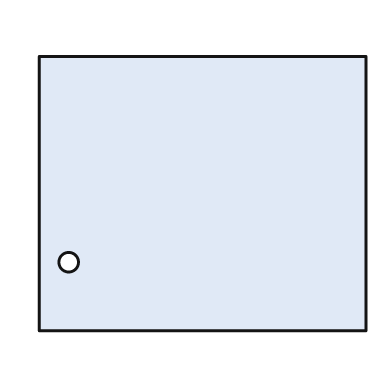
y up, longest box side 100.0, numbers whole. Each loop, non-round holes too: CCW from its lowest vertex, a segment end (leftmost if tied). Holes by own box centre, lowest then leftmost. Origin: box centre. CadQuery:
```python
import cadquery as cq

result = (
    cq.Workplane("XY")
    .moveTo(-50.0, -42.0)
    .lineTo(50.0, -42.0)
    .lineTo(50.0, 42.0)
    .lineTo(-50.0, 42.0)
    .close()
    .moveTo(-41.0, -21.0)
    .circle(3.0)
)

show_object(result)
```